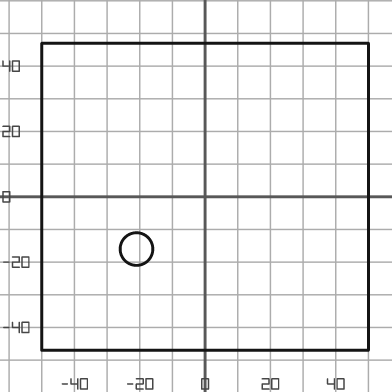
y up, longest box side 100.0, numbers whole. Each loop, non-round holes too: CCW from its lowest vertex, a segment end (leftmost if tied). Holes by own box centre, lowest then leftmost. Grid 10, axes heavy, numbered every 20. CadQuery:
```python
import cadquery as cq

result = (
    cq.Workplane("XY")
    .moveTo(-50.0, -47.0)
    .lineTo(50.0, -47.0)
    .lineTo(50.0, 47.0)
    .lineTo(-50.0, 47.0)
    .close()
    .moveTo(-21.0, -16.0)
    .circle(5.0)
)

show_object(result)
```